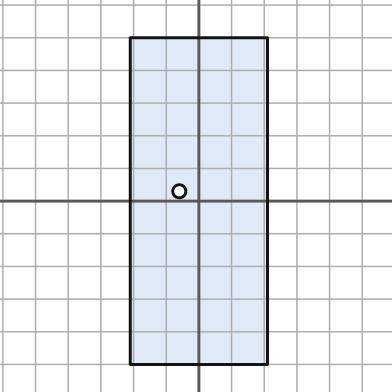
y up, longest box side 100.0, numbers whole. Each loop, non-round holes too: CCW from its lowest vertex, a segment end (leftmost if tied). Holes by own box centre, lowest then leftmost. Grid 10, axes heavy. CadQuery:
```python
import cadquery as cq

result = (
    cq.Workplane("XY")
    .moveTo(-21.0, -50.0)
    .lineTo(21.0, -50.0)
    .lineTo(21.0, 50.0)
    .lineTo(-21.0, 50.0)
    .close()
    .moveTo(-6.0, 3.0)
    .circle(2.0)
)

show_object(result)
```